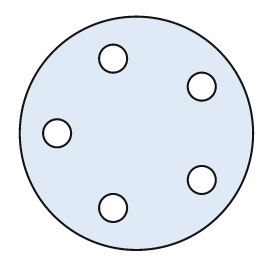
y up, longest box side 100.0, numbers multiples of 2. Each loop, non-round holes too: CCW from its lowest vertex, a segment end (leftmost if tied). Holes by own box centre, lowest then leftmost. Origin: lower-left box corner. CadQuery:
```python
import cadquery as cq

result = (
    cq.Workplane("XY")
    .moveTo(50.0, 50.0)
    .circle(50.0)
    .moveTo(40.0, 18.0)
    .circle(6.0)
    .moveTo(78.0, 30.0)
    .circle(6.0)
    .moveTo(16.0, 50.0)
    .circle(6.0)
    .moveTo(78.0, 70.0)
    .circle(6.0)
    .moveTo(40.0, 82.0)
    .circle(6.0)
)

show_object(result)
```